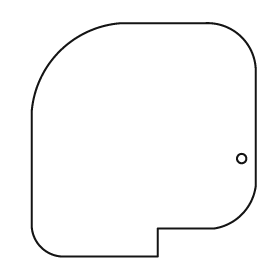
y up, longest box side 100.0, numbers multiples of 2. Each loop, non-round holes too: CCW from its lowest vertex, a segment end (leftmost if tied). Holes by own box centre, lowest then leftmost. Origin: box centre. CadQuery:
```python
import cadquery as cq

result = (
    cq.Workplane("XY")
    .moveTo(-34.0, -50.0)
    .lineTo(6.0, -50.0)
    .lineTo(6.0, -38.0)
    .lineTo(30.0, -38.0)
    .threePointArc((42.0, -32.0), (48.0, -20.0))
    .lineTo(48.0, 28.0)
    .threePointArc((42.0, 44.0), (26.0, 50.0))
    .lineTo(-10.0, 50.0)
    .threePointArc((-36.0, 38.0), (-48.0, 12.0))
    .lineTo(-48.0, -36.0)
    .threePointArc((-44.0, -46.0), (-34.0, -50.0))
    .close()
    .moveTo(42.0, -8.0)
    .circle(2.0)
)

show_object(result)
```